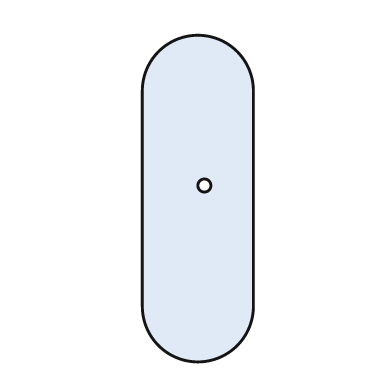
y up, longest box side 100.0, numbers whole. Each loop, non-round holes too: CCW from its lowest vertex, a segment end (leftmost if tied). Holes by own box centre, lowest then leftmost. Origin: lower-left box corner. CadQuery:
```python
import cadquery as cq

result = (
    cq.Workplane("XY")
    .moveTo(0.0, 17.0)
    .threePointArc((17.0, 0.0), (34.0, 17.0))
    .lineTo(34.0, 83.0)
    .threePointArc((17.0, 100.0), (0.0, 83.0))
    .close()
    .moveTo(19.0, 54.0)
    .circle(2.0)
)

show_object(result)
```